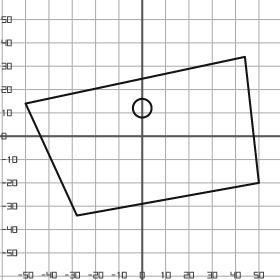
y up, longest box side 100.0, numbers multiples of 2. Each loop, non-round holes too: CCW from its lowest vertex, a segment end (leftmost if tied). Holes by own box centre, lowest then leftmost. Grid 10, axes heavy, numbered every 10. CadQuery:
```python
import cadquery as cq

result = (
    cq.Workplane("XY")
    .moveTo(-28.0, -34.0)
    .lineTo(50.0, -20.0)
    .lineTo(44.0, 34.0)
    .lineTo(-50.0, 14.0)
    .close()
    .moveTo(0.0, 12.0)
    .circle(4.0)
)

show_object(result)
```